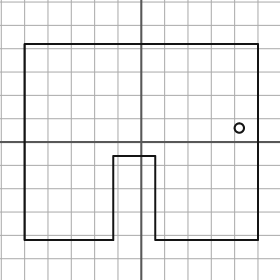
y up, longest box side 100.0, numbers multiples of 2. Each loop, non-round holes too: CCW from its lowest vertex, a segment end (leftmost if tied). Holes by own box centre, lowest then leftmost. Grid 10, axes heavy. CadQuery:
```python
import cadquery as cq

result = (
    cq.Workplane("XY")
    .moveTo(-50.0, -42.0)
    .lineTo(-12.0, -42.0)
    .lineTo(-12.0, -6.0)
    .lineTo(6.0, -6.0)
    .lineTo(6.0, -42.0)
    .lineTo(50.0, -42.0)
    .lineTo(50.0, 42.0)
    .lineTo(-50.0, 42.0)
    .close()
    .moveTo(42.0, 6.0)
    .circle(2.0)
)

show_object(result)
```